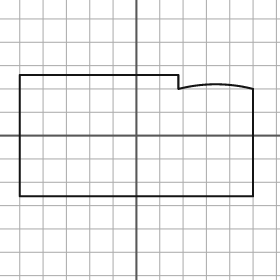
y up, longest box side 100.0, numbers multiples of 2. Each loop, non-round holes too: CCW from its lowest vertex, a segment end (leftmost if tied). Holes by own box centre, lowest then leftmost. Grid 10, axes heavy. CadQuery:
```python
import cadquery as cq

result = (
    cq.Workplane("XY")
    .moveTo(-50.0, -26.0)
    .lineTo(50.0, -26.0)
    .lineTo(50.0, 20.0)
    .threePointArc((34.0, 22.0), (18.0, 20.0))
    .lineTo(18.0, 26.0)
    .lineTo(-50.0, 26.0)
    .close()
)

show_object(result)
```